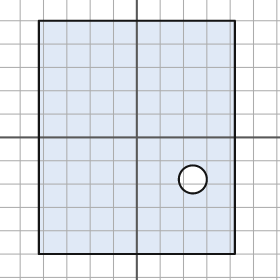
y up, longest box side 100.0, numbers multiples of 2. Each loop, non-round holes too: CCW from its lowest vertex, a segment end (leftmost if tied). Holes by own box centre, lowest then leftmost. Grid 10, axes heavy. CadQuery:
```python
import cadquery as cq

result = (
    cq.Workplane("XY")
    .moveTo(-42.0, -50.0)
    .lineTo(42.0, -50.0)
    .lineTo(42.0, 50.0)
    .lineTo(-42.0, 50.0)
    .close()
    .moveTo(24.0, -18.0)
    .circle(6.0)
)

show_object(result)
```